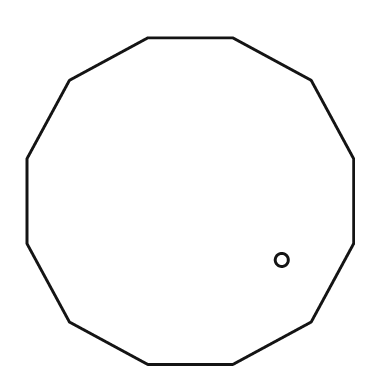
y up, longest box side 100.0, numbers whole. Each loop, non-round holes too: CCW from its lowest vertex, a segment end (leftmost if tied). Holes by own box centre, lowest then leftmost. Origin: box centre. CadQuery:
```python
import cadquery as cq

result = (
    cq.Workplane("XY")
    .moveTo(-13.0, -50.0)
    .lineTo(13.0, -50.0)
    .lineTo(37.0, -37.0)
    .lineTo(50.0, -13.0)
    .lineTo(50.0, 13.0)
    .lineTo(37.0, 37.0)
    .lineTo(13.0, 50.0)
    .lineTo(-13.0, 50.0)
    .lineTo(-37.0, 37.0)
    .lineTo(-50.0, 13.0)
    .lineTo(-50.0, -13.0)
    .lineTo(-37.0, -37.0)
    .close()
    .moveTo(28.0, -18.0)
    .circle(2.0)
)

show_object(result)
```